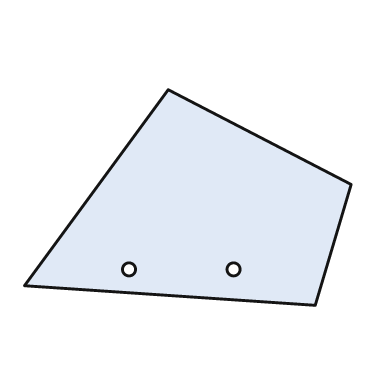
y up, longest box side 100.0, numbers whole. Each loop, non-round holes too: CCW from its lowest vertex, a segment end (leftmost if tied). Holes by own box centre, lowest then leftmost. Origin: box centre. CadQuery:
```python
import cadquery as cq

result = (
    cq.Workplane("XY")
    .moveTo(39.0, -33.0)
    .lineTo(50.0, 4.0)
    .lineTo(-6.0, 33.0)
    .lineTo(-50.0, -27.0)
    .close()
    .moveTo(-18.0, -22.0)
    .circle(2.0)
    .moveTo(14.0, -22.0)
    .circle(2.0)
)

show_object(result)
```